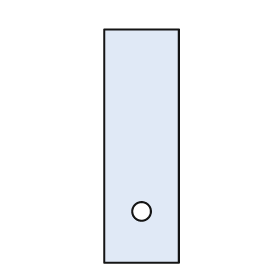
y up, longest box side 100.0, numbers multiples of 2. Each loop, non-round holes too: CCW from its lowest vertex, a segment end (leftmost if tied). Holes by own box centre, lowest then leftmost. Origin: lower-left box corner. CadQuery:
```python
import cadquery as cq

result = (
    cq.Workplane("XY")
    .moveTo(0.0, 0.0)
    .lineTo(32.0, 0.0)
    .lineTo(32.0, 100.0)
    .lineTo(0.0, 100.0)
    .close()
    .moveTo(16.0, 22.0)
    .circle(4.0)
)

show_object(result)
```